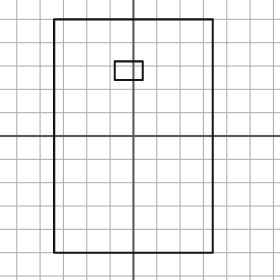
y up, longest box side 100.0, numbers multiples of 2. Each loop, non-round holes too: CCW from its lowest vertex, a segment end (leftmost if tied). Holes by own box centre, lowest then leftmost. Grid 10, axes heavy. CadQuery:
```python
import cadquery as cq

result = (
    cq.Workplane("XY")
    .moveTo(-34.0, -50.0)
    .lineTo(34.0, -50.0)
    .lineTo(34.0, 50.0)
    .lineTo(-34.0, 50.0)
    .close()
    .moveTo(-8.0, 24.0)
    .lineTo(4.0, 24.0)
    .lineTo(4.0, 32.0)
    .lineTo(-8.0, 32.0)
    .close()
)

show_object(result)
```